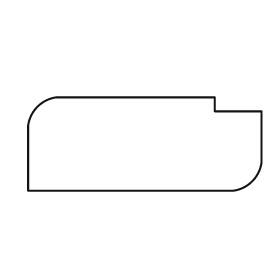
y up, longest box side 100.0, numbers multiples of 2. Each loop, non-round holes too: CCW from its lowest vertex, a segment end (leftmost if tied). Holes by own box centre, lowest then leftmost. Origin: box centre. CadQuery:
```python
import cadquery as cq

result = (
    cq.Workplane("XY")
    .moveTo(-50.0, -20.0)
    .lineTo(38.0, -20.0)
    .threePointArc((46.0, -16.0), (50.0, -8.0))
    .lineTo(50.0, 14.0)
    .lineTo(30.0, 14.0)
    .lineTo(30.0, 20.0)
    .lineTo(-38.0, 20.0)
    .threePointArc((-46.0, 16.0), (-50.0, 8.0))
    .close()
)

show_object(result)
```